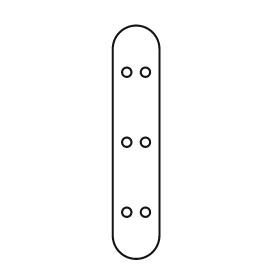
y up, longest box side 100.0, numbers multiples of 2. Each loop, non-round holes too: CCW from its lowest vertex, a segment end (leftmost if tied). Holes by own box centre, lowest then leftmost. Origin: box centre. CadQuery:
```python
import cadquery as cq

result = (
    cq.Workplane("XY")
    .moveTo(-10.0, -40.0)
    .threePointArc((0.0, -50.0), (10.0, -40.0))
    .lineTo(10.0, 40.0)
    .threePointArc((0.0, 50.0), (-10.0, 40.0))
    .close()
    .moveTo(-4.0, -30.0)
    .circle(2.0)
    .moveTo(4.0, -30.0)
    .circle(2.0)
    .moveTo(-4.0, 0.0)
    .circle(2.0)
    .moveTo(4.0, 0.0)
    .circle(2.0)
    .moveTo(-4.0, 30.0)
    .circle(2.0)
    .moveTo(4.0, 30.0)
    .circle(2.0)
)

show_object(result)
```